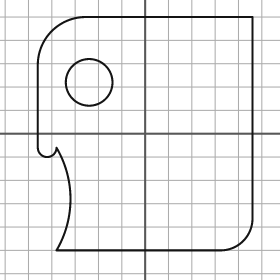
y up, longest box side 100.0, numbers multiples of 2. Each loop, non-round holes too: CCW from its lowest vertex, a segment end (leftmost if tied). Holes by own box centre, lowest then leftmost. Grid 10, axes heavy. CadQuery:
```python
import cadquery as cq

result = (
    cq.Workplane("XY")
    .moveTo(-38.0, -50.0)
    .lineTo(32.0, -50.0)
    .threePointArc((42.0, -46.0), (46.0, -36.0))
    .lineTo(46.0, 50.0)
    .lineTo(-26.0, 50.0)
    .threePointArc((-40.0, 44.0), (-46.0, 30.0))
    .lineTo(-46.0, -6.0)
    .threePointArc((-42.0, -10.0), (-38.0, -6.0))
    .threePointArc((-32.0, -28.0), (-38.0, -50.0))
    .close()
    .moveTo(-24.0, 22.0)
    .circle(10.0)
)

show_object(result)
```